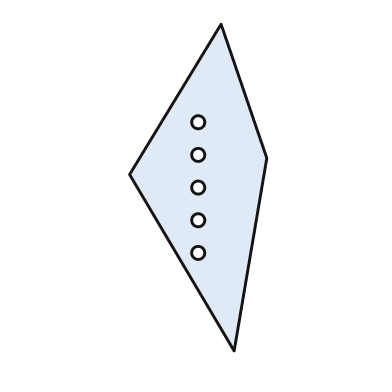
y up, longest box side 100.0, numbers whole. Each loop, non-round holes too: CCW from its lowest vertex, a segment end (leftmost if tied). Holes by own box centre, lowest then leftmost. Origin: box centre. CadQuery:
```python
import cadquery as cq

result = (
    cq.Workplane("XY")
    .moveTo(11.0, -50.0)
    .lineTo(21.0, 9.0)
    .lineTo(7.0, 50.0)
    .lineTo(-21.0, 4.0)
    .close()
    .moveTo(0.0, -20.0)
    .circle(2.0)
    .moveTo(0.0, -10.0)
    .circle(2.0)
    .moveTo(0.0, 0.0)
    .circle(2.0)
    .moveTo(0.0, 10.0)
    .circle(2.0)
    .moveTo(0.0, 20.0)
    .circle(2.0)
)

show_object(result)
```